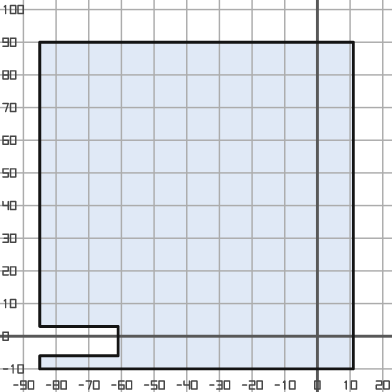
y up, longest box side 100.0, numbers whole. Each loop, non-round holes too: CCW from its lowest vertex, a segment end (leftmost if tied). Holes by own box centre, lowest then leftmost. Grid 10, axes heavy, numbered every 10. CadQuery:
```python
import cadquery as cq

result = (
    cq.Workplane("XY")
    .moveTo(-85.0, -10.0)
    .lineTo(11.0, -10.0)
    .lineTo(11.0, 90.0)
    .lineTo(-85.0, 90.0)
    .lineTo(-85.0, 3.0)
    .lineTo(-61.0, 3.0)
    .lineTo(-61.0, -6.0)
    .lineTo(-85.0, -6.0)
    .close()
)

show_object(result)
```